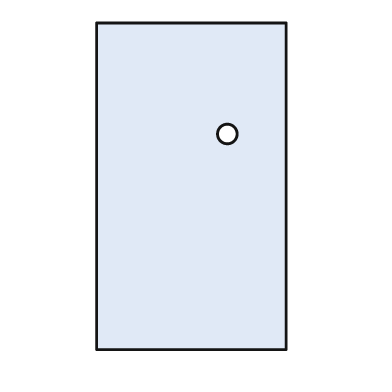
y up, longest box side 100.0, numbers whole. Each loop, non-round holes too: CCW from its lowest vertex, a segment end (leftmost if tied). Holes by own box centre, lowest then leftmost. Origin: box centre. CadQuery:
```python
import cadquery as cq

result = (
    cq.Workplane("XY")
    .moveTo(-29.0, -50.0)
    .lineTo(29.0, -50.0)
    .lineTo(29.0, 50.0)
    .lineTo(-29.0, 50.0)
    .close()
    .moveTo(11.0, 16.0)
    .circle(3.0)
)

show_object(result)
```